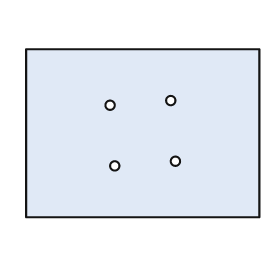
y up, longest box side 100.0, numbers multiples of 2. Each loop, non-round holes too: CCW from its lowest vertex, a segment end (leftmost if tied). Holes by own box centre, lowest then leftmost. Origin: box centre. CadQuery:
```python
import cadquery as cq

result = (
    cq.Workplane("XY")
    .moveTo(-50.0, -36.0)
    .lineTo(50.0, -36.0)
    .lineTo(50.0, 36.0)
    .lineTo(-50.0, 36.0)
    .close()
    .moveTo(-12.0, -14.0)
    .circle(2.0)
    .moveTo(14.0, -12.0)
    .circle(2.0)
    .moveTo(-14.0, 12.0)
    .circle(2.0)
    .moveTo(12.0, 14.0)
    .circle(2.0)
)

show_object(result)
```